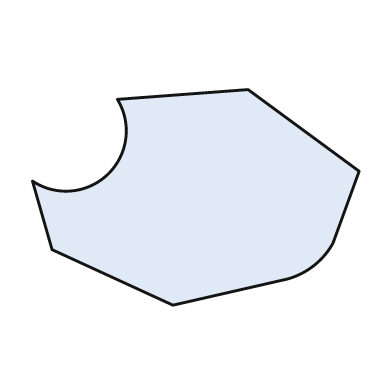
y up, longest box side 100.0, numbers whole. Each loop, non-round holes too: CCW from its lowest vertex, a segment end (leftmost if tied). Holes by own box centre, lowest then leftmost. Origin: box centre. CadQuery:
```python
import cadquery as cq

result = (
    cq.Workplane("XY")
    .moveTo(-7.0, -33.0)
    .lineTo(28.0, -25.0)
    .threePointArc((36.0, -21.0), (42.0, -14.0))
    .lineTo(50.0, 8.0)
    .lineTo(16.0, 33.0)
    .lineTo(-24.0, 30.0)
    .threePointArc((-27.0, 7.0), (-50.0, 5.0))
    .lineTo(-44.0, -16.0)
    .close()
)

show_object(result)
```